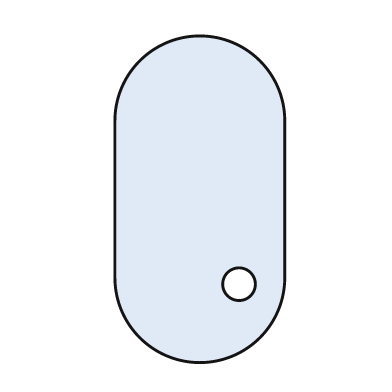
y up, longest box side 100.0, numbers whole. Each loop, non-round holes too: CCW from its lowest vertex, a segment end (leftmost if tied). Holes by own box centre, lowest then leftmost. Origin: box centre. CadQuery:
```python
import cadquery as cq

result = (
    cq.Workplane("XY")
    .moveTo(-26.0, -24.0)
    .threePointArc((0.0, -50.0), (26.0, -24.0))
    .lineTo(26.0, 24.0)
    .threePointArc((0.0, 50.0), (-26.0, 24.0))
    .close()
    .moveTo(12.0, -26.0)
    .circle(5.0)
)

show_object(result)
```